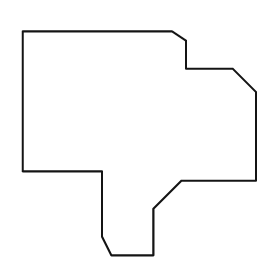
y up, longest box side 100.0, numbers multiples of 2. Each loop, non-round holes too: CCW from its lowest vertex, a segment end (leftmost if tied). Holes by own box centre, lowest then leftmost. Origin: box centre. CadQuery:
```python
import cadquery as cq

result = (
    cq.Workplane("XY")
    .moveTo(-12.0, -48.0)
    .lineTo(6.0, -48.0)
    .lineTo(6.0, -28.0)
    .lineTo(18.0, -16.0)
    .lineTo(50.0, -16.0)
    .lineTo(50.0, 22.0)
    .lineTo(40.0, 32.0)
    .lineTo(20.0, 32.0)
    .lineTo(20.0, 44.0)
    .lineTo(14.0, 48.0)
    .lineTo(-50.0, 48.0)
    .lineTo(-50.0, -12.0)
    .lineTo(-16.0, -12.0)
    .lineTo(-16.0, -40.0)
    .close()
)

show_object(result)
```